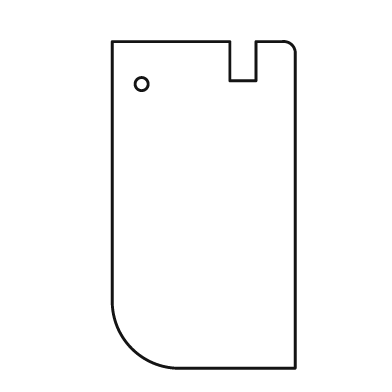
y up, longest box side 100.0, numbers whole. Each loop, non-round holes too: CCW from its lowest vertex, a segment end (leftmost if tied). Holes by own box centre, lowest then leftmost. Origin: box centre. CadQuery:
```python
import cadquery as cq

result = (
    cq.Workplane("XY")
    .moveTo(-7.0, -50.0)
    .lineTo(28.0, -50.0)
    .lineTo(28.0, 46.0)
    .threePointArc((27.0, 49.0), (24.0, 50.0))
    .lineTo(16.0, 50.0)
    .lineTo(16.0, 38.0)
    .lineTo(8.0, 38.0)
    .lineTo(8.0, 50.0)
    .lineTo(-28.0, 50.0)
    .lineTo(-28.0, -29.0)
    .threePointArc((-22.0, -44.0), (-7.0, -50.0))
    .close()
    .moveTo(-19.0, 37.0)
    .circle(2.0)
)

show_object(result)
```